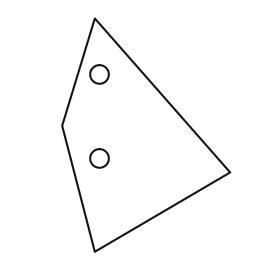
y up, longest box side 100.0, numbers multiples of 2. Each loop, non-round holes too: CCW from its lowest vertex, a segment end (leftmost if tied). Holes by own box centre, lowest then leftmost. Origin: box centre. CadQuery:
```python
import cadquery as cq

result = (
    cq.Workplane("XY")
    .moveTo(-22.0, -50.0)
    .lineTo(36.0, -16.0)
    .lineTo(-22.0, 50.0)
    .lineTo(-36.0, 4.0)
    .close()
    .moveTo(-20.0, -10.0)
    .circle(4.0)
    .moveTo(-20.0, 26.0)
    .circle(4.0)
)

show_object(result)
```